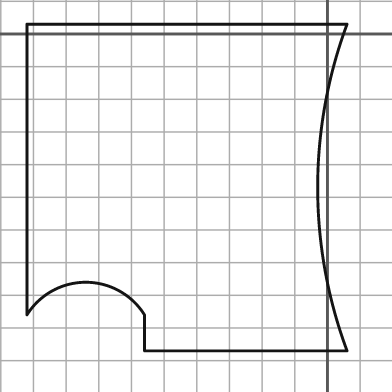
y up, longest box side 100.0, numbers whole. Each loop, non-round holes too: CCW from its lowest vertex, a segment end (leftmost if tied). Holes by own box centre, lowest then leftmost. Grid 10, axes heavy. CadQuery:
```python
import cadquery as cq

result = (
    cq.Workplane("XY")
    .moveTo(-56.0, -97.0)
    .lineTo(6.0, -97.0)
    .threePointArc((-3.0, -47.0), (6.0, 3.0))
    .lineTo(-92.0, 3.0)
    .lineTo(-92.0, -86.0)
    .threePointArc((-74.0, -76.0), (-56.0, -86.0))
    .close()
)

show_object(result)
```